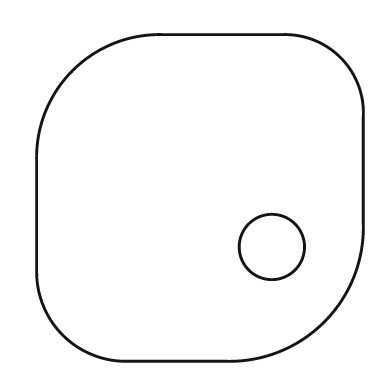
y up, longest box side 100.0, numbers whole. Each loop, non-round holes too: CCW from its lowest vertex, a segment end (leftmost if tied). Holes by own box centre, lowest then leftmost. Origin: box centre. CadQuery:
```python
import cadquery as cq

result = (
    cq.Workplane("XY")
    .moveTo(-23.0, -50.0)
    .lineTo(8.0, -50.0)
    .threePointArc((38.0, -38.0), (50.0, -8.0))
    .lineTo(50.0, 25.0)
    .threePointArc((43.0, 43.0), (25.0, 50.0))
    .lineTo(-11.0, 50.0)
    .threePointArc((-39.0, 39.0), (-50.0, 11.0))
    .lineTo(-50.0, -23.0)
    .threePointArc((-42.0, -42.0), (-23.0, -50.0))
    .close()
    .moveTo(22.0, -15.0)
    .circle(10.0)
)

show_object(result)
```